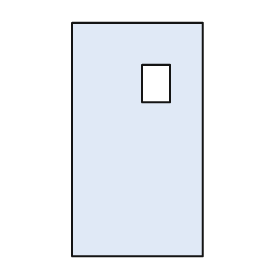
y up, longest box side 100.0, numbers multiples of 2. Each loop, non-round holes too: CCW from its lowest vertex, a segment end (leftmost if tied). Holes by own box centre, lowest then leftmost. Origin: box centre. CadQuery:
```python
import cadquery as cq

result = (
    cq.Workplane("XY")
    .moveTo(-28.0, -50.0)
    .lineTo(28.0, -50.0)
    .lineTo(28.0, 50.0)
    .lineTo(-28.0, 50.0)
    .close()
    .moveTo(2.0, 16.0)
    .lineTo(14.0, 16.0)
    .lineTo(14.0, 32.0)
    .lineTo(2.0, 32.0)
    .close()
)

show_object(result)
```